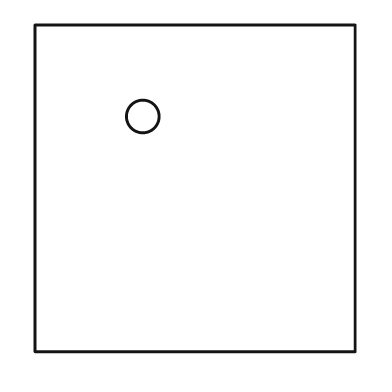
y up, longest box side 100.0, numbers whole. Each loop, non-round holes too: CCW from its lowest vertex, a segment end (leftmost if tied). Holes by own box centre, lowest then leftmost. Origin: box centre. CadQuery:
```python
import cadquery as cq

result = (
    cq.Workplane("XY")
    .moveTo(-49.0, -50.0)
    .lineTo(49.0, -50.0)
    .lineTo(49.0, 50.0)
    .lineTo(-49.0, 50.0)
    .close()
    .moveTo(-16.0, 22.0)
    .circle(5.0)
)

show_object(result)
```